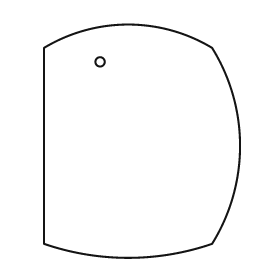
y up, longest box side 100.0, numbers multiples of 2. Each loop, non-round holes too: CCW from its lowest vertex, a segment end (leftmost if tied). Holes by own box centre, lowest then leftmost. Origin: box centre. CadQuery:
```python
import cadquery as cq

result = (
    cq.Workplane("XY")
    .moveTo(-42.0, -44.0)
    .threePointArc((-6.0, -50.0), (30.0, -44.0))
    .threePointArc((42.0, -2.0), (30.0, 40.0))
    .threePointArc((-6.0, 50.0), (-42.0, 40.0))
    .close()
    .moveTo(-18.0, 34.0)
    .circle(2.0)
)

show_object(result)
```